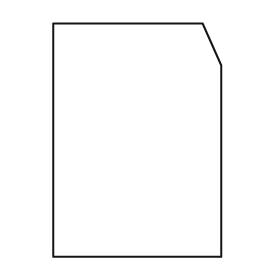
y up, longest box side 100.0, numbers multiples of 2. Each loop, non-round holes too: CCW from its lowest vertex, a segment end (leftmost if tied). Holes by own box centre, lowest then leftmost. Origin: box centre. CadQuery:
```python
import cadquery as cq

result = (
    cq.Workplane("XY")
    .moveTo(-36.0, -50.0)
    .lineTo(36.0, -50.0)
    .lineTo(36.0, 32.0)
    .lineTo(28.0, 50.0)
    .lineTo(-36.0, 50.0)
    .close()
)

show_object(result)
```